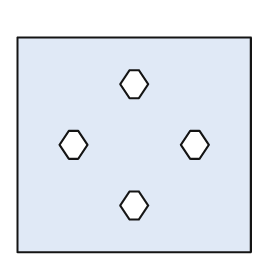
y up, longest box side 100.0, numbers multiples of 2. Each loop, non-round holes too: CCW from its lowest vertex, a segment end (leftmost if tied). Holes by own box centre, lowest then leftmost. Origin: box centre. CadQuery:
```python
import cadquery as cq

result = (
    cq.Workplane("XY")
    .moveTo(-50.0, -46.0)
    .lineTo(50.0, -46.0)
    .lineTo(50.0, 46.0)
    .lineTo(-50.0, 46.0)
    .close()
    .moveTo(-2.0, -32.0)
    .lineTo(2.0, -32.0)
    .lineTo(6.0, -26.0)
    .lineTo(2.0, -20.0)
    .lineTo(-2.0, -20.0)
    .lineTo(-6.0, -26.0)
    .close()
    .moveTo(-28.0, -6.0)
    .lineTo(-24.0, -6.0)
    .lineTo(-20.0, 0.0)
    .lineTo(-24.0, 6.0)
    .lineTo(-28.0, 6.0)
    .lineTo(-32.0, 0.0)
    .close()
    .moveTo(24.0, -6.0)
    .lineTo(28.0, -6.0)
    .lineTo(32.0, 0.0)
    .lineTo(28.0, 6.0)
    .lineTo(24.0, 6.0)
    .lineTo(20.0, 0.0)
    .close()
    .moveTo(-2.0, 20.0)
    .lineTo(2.0, 20.0)
    .lineTo(6.0, 26.0)
    .lineTo(2.0, 32.0)
    .lineTo(-2.0, 32.0)
    .lineTo(-6.0, 26.0)
    .close()
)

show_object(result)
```